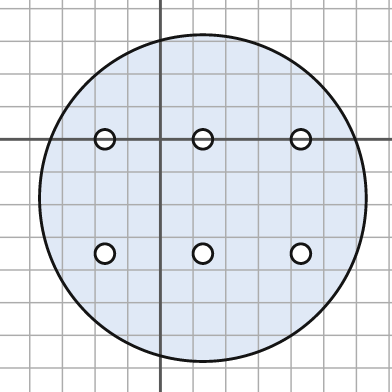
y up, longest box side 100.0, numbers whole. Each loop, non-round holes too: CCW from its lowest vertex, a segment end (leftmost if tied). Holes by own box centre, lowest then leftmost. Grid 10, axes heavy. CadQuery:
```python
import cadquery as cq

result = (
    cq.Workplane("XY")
    .moveTo(13.0, -18.0)
    .circle(50.0)
    .moveTo(-17.0, -35.0)
    .circle(3.0)
    .moveTo(13.0, -35.0)
    .circle(3.0)
    .moveTo(43.0, -35.0)
    .circle(3.0)
    .moveTo(-17.0, 0.0)
    .circle(3.0)
    .moveTo(13.0, 0.0)
    .circle(3.0)
    .moveTo(43.0, 0.0)
    .circle(3.0)
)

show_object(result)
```